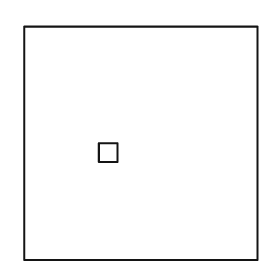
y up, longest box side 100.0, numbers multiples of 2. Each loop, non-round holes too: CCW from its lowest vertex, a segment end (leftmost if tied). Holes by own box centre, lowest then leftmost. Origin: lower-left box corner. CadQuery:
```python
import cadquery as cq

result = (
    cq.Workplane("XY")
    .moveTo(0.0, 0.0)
    .lineTo(100.0, 0.0)
    .lineTo(100.0, 100.0)
    .lineTo(0.0, 100.0)
    .close()
    .moveTo(32.0, 42.0)
    .lineTo(40.0, 42.0)
    .lineTo(40.0, 50.0)
    .lineTo(32.0, 50.0)
    .close()
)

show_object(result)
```